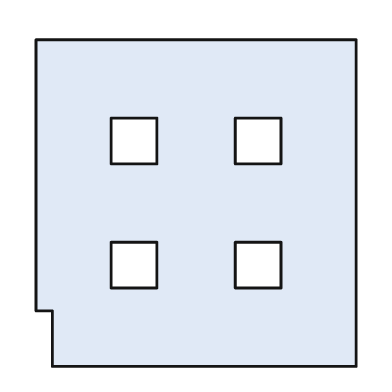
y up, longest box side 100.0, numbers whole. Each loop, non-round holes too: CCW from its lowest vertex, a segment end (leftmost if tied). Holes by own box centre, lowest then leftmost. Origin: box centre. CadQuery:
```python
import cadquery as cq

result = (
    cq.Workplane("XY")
    .moveTo(-44.0, -50.0)
    .lineTo(49.0, -50.0)
    .lineTo(49.0, 50.0)
    .lineTo(-49.0, 50.0)
    .lineTo(-49.0, -33.0)
    .lineTo(-44.0, -33.0)
    .close()
    .moveTo(-26.0, -26.0)
    .lineTo(-12.0, -26.0)
    .lineTo(-12.0, -12.0)
    .lineTo(-26.0, -12.0)
    .close()
    .moveTo(12.0, -26.0)
    .lineTo(26.0, -26.0)
    .lineTo(26.0, -12.0)
    .lineTo(12.0, -12.0)
    .close()
    .moveTo(-26.0, 12.0)
    .lineTo(-12.0, 12.0)
    .lineTo(-12.0, 26.0)
    .lineTo(-26.0, 26.0)
    .close()
    .moveTo(12.0, 12.0)
    .lineTo(26.0, 12.0)
    .lineTo(26.0, 26.0)
    .lineTo(12.0, 26.0)
    .close()
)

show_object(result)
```